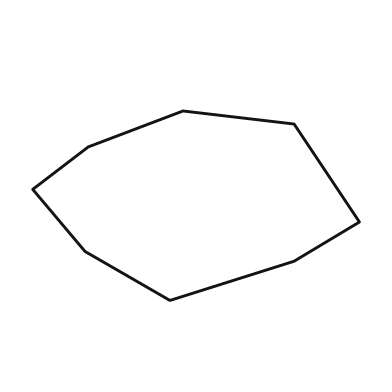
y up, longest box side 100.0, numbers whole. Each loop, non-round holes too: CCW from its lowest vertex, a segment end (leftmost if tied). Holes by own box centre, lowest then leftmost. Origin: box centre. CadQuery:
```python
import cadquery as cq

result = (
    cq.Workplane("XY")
    .moveTo(-8.0, -29.0)
    .lineTo(30.0, -17.0)
    .lineTo(50.0, -5.0)
    .lineTo(30.0, 25.0)
    .lineTo(-4.0, 29.0)
    .lineTo(-33.0, 18.0)
    .lineTo(-50.0, 5.0)
    .lineTo(-34.0, -14.0)
    .close()
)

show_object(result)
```